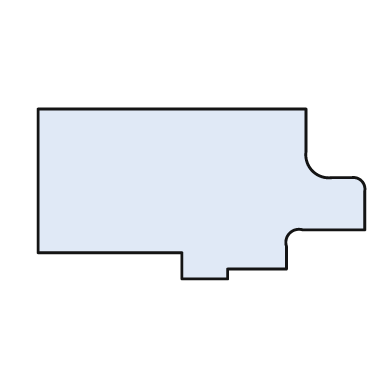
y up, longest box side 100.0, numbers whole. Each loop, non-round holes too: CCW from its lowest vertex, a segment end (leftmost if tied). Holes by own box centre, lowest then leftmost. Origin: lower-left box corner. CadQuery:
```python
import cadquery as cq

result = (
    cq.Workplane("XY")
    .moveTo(44.0, 0.0)
    .lineTo(58.0, 0.0)
    .lineTo(58.0, 3.0)
    .lineTo(76.0, 3.0)
    .lineTo(76.0, 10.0)
    .threePointArc((77.0, 14.0), (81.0, 15.0))
    .lineTo(100.0, 15.0)
    .lineTo(100.0, 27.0)
    .threePointArc((99.0, 30.0), (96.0, 31.0))
    .lineTo(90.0, 31.0)
    .threePointArc((84.0, 33.0), (82.0, 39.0))
    .lineTo(82.0, 52.0)
    .lineTo(0.0, 52.0)
    .lineTo(0.0, 8.0)
    .lineTo(44.0, 8.0)
    .close()
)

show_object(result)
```